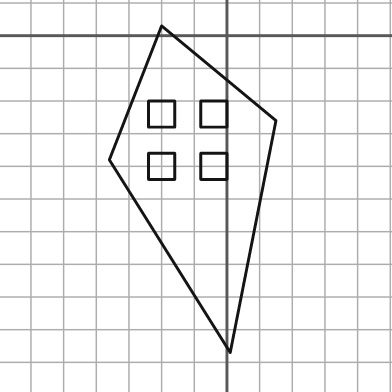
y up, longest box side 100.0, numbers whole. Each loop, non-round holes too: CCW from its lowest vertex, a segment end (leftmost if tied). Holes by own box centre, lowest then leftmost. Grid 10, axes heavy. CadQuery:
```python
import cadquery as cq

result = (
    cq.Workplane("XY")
    .moveTo(1.0, -97.0)
    .lineTo(15.0, -26.0)
    .lineTo(-20.0, 3.0)
    .lineTo(-36.0, -38.0)
    .close()
    .moveTo(-24.0, -44.0)
    .lineTo(-16.0, -44.0)
    .lineTo(-16.0, -36.0)
    .lineTo(-24.0, -36.0)
    .close()
    .moveTo(-8.0, -44.0)
    .lineTo(0.0, -44.0)
    .lineTo(0.0, -36.0)
    .lineTo(-8.0, -36.0)
    .close()
    .moveTo(-24.0, -28.0)
    .lineTo(-16.0, -28.0)
    .lineTo(-16.0, -20.0)
    .lineTo(-24.0, -20.0)
    .close()
    .moveTo(-8.0, -28.0)
    .lineTo(0.0, -28.0)
    .lineTo(0.0, -20.0)
    .lineTo(-8.0, -20.0)
    .close()
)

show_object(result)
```